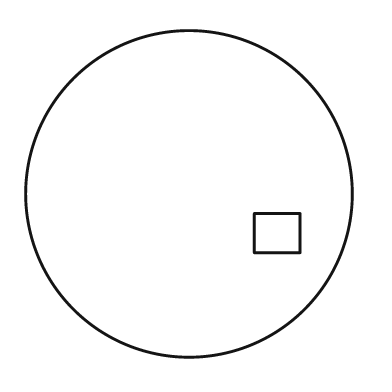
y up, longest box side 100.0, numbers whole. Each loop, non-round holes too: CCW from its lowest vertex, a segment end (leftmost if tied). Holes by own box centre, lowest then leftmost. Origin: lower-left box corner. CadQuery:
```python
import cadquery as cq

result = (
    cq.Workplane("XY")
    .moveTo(50.0, 50.0)
    .circle(50.0)
    .moveTo(70.0, 32.0)
    .lineTo(84.0, 32.0)
    .lineTo(84.0, 44.0)
    .lineTo(70.0, 44.0)
    .close()
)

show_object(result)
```